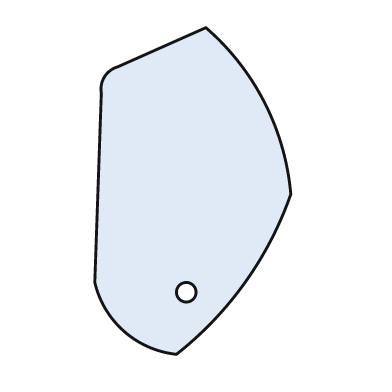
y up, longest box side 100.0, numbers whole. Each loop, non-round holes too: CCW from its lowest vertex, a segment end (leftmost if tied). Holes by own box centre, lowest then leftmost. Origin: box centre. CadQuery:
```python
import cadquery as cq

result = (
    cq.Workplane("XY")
    .moveTo(-5.0, -50.0)
    .threePointArc((16.0, -28.0), (30.0, -1.0))
    .threePointArc((22.0, 27.0), (4.0, 50.0))
    .lineTo(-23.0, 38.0)
    .threePointArc((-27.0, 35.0), (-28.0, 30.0))
    .lineTo(-30.0, -28.0)
    .threePointArc((-21.0, -43.0), (-5.0, -50.0))
    .close()
    .moveTo(-2.0, -31.0)
    .circle(3.0)
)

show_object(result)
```